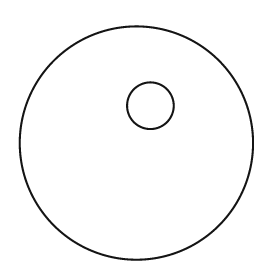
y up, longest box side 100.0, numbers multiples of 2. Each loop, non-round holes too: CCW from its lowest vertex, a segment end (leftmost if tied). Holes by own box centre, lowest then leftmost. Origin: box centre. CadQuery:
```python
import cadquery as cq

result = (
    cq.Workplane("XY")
    .moveTo(0.0, 0.0)
    .circle(50.0)
    .moveTo(6.0, 16.0)
    .circle(10.0)
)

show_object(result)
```